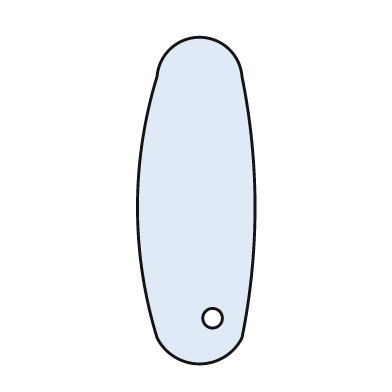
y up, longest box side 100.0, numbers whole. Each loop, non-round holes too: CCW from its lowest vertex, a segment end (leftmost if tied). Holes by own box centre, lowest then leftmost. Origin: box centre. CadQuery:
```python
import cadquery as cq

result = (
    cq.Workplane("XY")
    .moveTo(-12.0, -42.0)
    .threePointArc((1.0, -50.0), (14.0, -42.0))
    .threePointArc((18.0, -2.0), (14.0, 38.0))
    .threePointArc((1.0, 50.0), (-12.0, 38.0))
    .threePointArc((-18.0, -2.0), (-12.0, -42.0))
    .close()
    .moveTo(5.0, -36.0)
    .circle(3.0)
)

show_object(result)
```